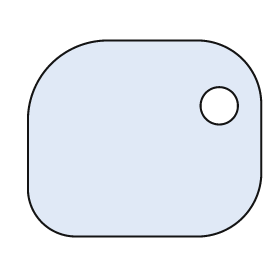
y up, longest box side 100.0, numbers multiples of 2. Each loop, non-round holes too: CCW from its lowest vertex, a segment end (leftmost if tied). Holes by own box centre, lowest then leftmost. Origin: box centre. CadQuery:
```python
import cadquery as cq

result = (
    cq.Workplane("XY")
    .moveTo(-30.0, -42.0)
    .lineTo(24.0, -42.0)
    .threePointArc((42.0, -34.0), (50.0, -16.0))
    .lineTo(50.0, 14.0)
    .threePointArc((42.0, 34.0), (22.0, 42.0))
    .lineTo(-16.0, 42.0)
    .threePointArc((-40.0, 32.0), (-50.0, 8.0))
    .lineTo(-50.0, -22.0)
    .threePointArc((-44.0, -36.0), (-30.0, -42.0))
    .close()
    .moveTo(32.0, 14.0)
    .circle(8.0)
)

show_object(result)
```